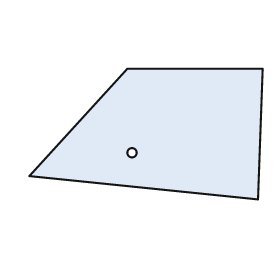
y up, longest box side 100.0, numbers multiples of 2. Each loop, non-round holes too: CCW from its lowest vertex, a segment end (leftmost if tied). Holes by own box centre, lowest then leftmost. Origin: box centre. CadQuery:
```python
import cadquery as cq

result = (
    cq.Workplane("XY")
    .moveTo(48.0, -28.0)
    .lineTo(50.0, 28.0)
    .lineTo(-8.0, 28.0)
    .lineTo(-50.0, -18.0)
    .close()
    .moveTo(-6.0, -8.0)
    .circle(2.0)
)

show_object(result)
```